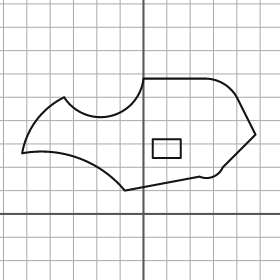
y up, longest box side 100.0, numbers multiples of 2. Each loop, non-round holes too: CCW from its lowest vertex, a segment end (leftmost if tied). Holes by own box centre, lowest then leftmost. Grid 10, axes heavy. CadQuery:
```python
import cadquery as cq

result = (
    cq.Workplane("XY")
    .moveTo(-8.0, 10.0)
    .lineTo(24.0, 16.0)
    .threePointArc((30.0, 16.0), (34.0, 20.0))
    .lineTo(48.0, 34.0)
    .lineTo(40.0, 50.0)
    .threePointArc((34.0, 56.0), (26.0, 58.0))
    .lineTo(0.0, 58.0)
    .threePointArc((-14.0, 42.0), (-34.0, 50.0))
    .threePointArc((-46.0, 40.0), (-52.0, 26.0))
    .threePointArc((-28.0, 24.0), (-8.0, 10.0))
    .close()
    .moveTo(4.0, 24.0)
    .lineTo(16.0, 24.0)
    .lineTo(16.0, 32.0)
    .lineTo(4.0, 32.0)
    .close()
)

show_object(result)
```